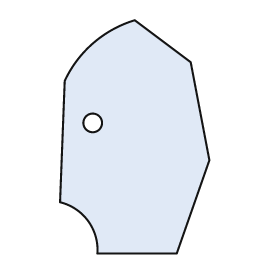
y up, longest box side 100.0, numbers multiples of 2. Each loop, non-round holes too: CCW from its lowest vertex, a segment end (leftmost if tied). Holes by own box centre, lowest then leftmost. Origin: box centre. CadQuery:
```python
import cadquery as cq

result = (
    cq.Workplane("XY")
    .moveTo(-16.0, -50.0)
    .lineTo(18.0, -50.0)
    .lineTo(32.0, -10.0)
    .lineTo(24.0, 32.0)
    .lineTo(0.0, 50.0)
    .threePointArc((-18.0, 40.0), (-30.0, 24.0))
    .lineTo(-32.0, -28.0)
    .threePointArc((-20.0, -36.0), (-16.0, -50.0))
    .close()
    .moveTo(-18.0, 6.0)
    .circle(4.0)
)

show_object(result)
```